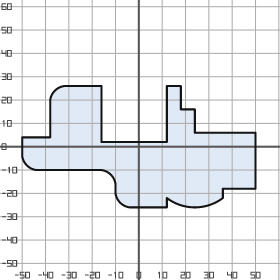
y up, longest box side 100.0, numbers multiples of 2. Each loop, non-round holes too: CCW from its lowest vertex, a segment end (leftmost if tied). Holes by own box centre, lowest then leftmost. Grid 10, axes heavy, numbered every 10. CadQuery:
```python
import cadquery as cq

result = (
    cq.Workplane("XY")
    .moveTo(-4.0, -26.0)
    .lineTo(12.0, -26.0)
    .lineTo(12.0, -22.0)
    .threePointArc((24.0, -26.0), (36.0, -22.0))
    .lineTo(36.0, -18.0)
    .lineTo(50.0, -18.0)
    .lineTo(50.0, 6.0)
    .lineTo(24.0, 6.0)
    .lineTo(24.0, 16.0)
    .lineTo(18.0, 16.0)
    .lineTo(18.0, 26.0)
    .lineTo(12.0, 26.0)
    .lineTo(12.0, 2.0)
    .lineTo(-16.0, 2.0)
    .lineTo(-16.0, 26.0)
    .lineTo(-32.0, 26.0)
    .threePointArc((-36.0, 24.0), (-38.0, 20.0))
    .lineTo(-38.0, 4.0)
    .lineTo(-50.0, 4.0)
    .lineTo(-50.0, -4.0)
    .threePointArc((-48.0, -8.0), (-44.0, -10.0))
    .lineTo(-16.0, -10.0)
    .threePointArc((-12.0, -12.0), (-10.0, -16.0))
    .lineTo(-10.0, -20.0)
    .threePointArc((-8.0, -24.0), (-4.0, -26.0))
    .close()
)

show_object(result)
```